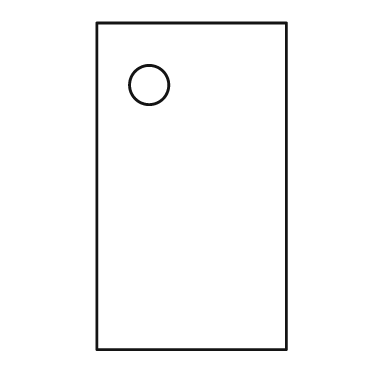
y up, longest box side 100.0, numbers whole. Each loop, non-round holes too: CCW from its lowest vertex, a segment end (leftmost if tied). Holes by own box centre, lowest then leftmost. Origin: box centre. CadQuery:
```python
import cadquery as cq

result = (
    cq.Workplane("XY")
    .moveTo(-29.0, -50.0)
    .lineTo(29.0, -50.0)
    .lineTo(29.0, 50.0)
    .lineTo(-29.0, 50.0)
    .close()
    .moveTo(-13.0, 31.0)
    .circle(6.0)
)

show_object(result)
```